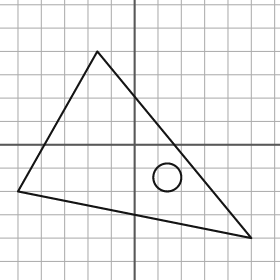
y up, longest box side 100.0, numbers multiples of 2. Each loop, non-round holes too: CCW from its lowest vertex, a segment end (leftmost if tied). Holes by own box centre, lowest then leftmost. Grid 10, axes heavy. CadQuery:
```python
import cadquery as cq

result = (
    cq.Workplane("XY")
    .moveTo(50.0, -40.0)
    .lineTo(-16.0, 40.0)
    .lineTo(-50.0, -20.0)
    .close()
    .moveTo(14.0, -14.0)
    .circle(6.0)
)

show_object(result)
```